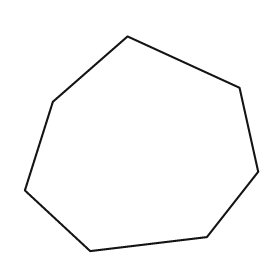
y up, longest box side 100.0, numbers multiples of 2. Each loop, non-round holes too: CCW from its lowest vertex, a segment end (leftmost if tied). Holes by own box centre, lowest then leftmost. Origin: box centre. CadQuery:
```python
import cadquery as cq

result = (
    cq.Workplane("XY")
    .moveTo(-22.0, -46.0)
    .lineTo(28.0, -40.0)
    .lineTo(50.0, -12.0)
    .lineTo(42.0, 24.0)
    .lineTo(-6.0, 46.0)
    .lineTo(-38.0, 18.0)
    .lineTo(-50.0, -20.0)
    .close()
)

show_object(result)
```